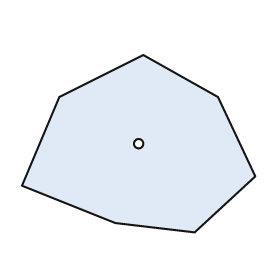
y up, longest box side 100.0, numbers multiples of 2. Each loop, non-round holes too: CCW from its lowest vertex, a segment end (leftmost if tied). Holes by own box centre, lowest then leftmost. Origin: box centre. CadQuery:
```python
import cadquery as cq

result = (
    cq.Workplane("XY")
    .moveTo(24.0, -38.0)
    .lineTo(50.0, -14.0)
    .lineTo(34.0, 20.0)
    .lineTo(2.0, 38.0)
    .lineTo(-34.0, 20.0)
    .lineTo(-50.0, -18.0)
    .lineTo(-10.0, -34.0)
    .close()
    .moveTo(0.0, 0.0)
    .circle(2.0)
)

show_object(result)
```